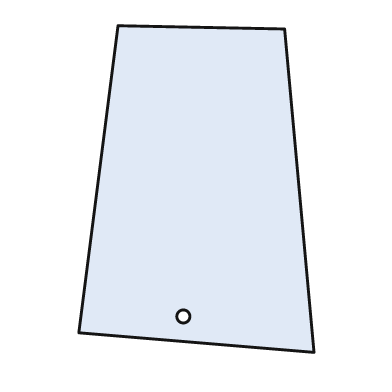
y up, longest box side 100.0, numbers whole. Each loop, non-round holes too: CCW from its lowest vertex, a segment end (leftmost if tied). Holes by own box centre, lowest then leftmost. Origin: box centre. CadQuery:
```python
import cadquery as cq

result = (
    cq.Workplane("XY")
    .moveTo(36.0, -50.0)
    .lineTo(27.0, 49.0)
    .lineTo(-24.0, 50.0)
    .lineTo(-36.0, -44.0)
    .close()
    .moveTo(-4.0, -39.0)
    .circle(2.0)
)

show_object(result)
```